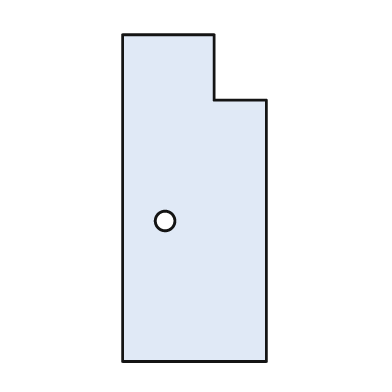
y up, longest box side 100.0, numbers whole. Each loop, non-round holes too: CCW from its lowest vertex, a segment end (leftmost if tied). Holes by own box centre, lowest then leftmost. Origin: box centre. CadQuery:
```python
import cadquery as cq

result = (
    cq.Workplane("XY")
    .moveTo(-22.0, -50.0)
    .lineTo(22.0, -50.0)
    .lineTo(22.0, 30.0)
    .lineTo(6.0, 30.0)
    .lineTo(6.0, 50.0)
    .lineTo(-22.0, 50.0)
    .close()
    .moveTo(-9.0, -7.0)
    .circle(3.0)
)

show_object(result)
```